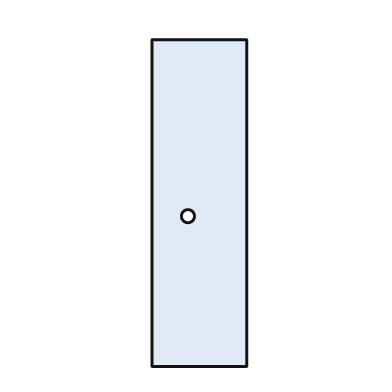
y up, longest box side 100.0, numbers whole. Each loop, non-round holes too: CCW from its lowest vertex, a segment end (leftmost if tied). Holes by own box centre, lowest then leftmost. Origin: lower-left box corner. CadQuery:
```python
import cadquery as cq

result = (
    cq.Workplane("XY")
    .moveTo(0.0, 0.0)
    .lineTo(29.0, 0.0)
    .lineTo(29.0, 100.0)
    .lineTo(0.0, 100.0)
    .close()
    .moveTo(11.0, 46.0)
    .circle(2.0)
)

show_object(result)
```